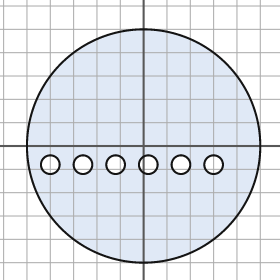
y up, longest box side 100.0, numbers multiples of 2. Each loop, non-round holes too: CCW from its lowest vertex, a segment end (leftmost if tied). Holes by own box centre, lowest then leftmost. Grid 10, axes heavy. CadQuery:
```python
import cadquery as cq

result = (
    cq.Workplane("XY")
    .moveTo(0.0, 0.0)
    .circle(50.0)
    .moveTo(-40.0, -8.0)
    .circle(4.0)
    .moveTo(-26.0, -8.0)
    .circle(4.0)
    .moveTo(-12.0, -8.0)
    .circle(4.0)
    .moveTo(2.0, -8.0)
    .circle(4.0)
    .moveTo(16.0, -8.0)
    .circle(4.0)
    .moveTo(30.0, -8.0)
    .circle(4.0)
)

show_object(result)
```